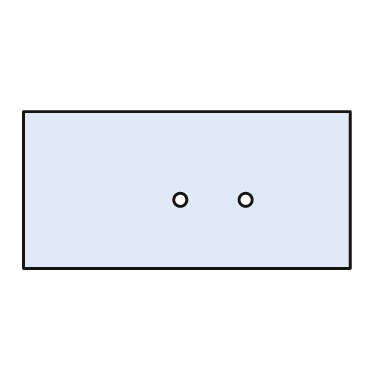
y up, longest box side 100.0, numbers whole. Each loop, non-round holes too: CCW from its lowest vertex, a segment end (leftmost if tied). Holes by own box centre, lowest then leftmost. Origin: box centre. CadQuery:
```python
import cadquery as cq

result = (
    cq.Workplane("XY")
    .moveTo(-50.0, -24.0)
    .lineTo(50.0, -24.0)
    .lineTo(50.0, 24.0)
    .lineTo(-50.0, 24.0)
    .close()
    .moveTo(-2.0, -3.0)
    .circle(2.0)
    .moveTo(18.0, -3.0)
    .circle(2.0)
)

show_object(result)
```